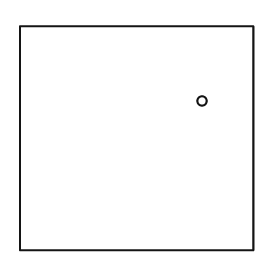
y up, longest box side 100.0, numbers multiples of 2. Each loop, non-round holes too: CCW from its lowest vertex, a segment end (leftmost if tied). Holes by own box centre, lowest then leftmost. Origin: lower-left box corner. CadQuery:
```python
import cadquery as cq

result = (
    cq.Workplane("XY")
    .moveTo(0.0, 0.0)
    .lineTo(100.0, 0.0)
    .lineTo(100.0, 96.0)
    .lineTo(0.0, 96.0)
    .close()
    .moveTo(78.0, 64.0)
    .circle(2.0)
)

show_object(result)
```